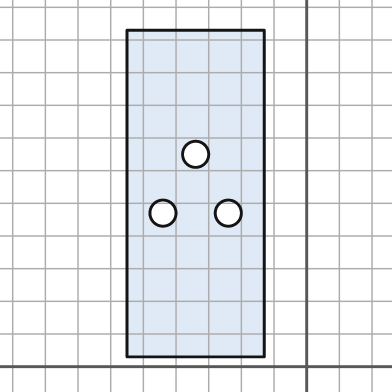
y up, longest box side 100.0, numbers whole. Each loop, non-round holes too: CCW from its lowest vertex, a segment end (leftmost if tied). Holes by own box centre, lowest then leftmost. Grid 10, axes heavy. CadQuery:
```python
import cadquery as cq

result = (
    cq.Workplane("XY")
    .moveTo(-55.0, 3.0)
    .lineTo(-13.0, 3.0)
    .lineTo(-13.0, 103.0)
    .lineTo(-55.0, 103.0)
    .close()
    .moveTo(-44.0, 47.0)
    .circle(4.0)
    .moveTo(-24.0, 47.0)
    .circle(4.0)
    .moveTo(-34.0, 65.0)
    .circle(4.0)
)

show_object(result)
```